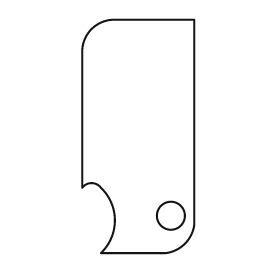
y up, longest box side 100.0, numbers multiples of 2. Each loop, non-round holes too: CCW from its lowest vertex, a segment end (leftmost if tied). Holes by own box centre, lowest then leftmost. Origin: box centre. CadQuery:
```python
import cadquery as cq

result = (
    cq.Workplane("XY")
    .moveTo(-16.0, -50.0)
    .lineTo(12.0, -50.0)
    .threePointArc((20.0, -46.0), (24.0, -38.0))
    .lineTo(24.0, 50.0)
    .lineTo(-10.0, 50.0)
    .threePointArc((-20.0, 46.0), (-24.0, 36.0))
    .lineTo(-24.0, -22.0)
    .threePointArc((-20.0, -20.0), (-16.0, -22.0))
    .threePointArc((-10.0, -36.0), (-16.0, -50.0))
    .close()
    .moveTo(14.0, -34.0)
    .circle(6.0)
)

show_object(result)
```